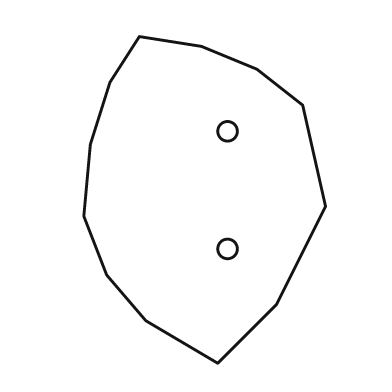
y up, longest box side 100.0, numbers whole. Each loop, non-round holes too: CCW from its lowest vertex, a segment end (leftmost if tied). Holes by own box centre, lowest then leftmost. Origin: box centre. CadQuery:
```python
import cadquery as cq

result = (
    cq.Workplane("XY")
    .moveTo(4.0, -50.0)
    .lineTo(22.0, -32.0)
    .lineTo(37.0, -2.0)
    .lineTo(30.0, 29.0)
    .lineTo(16.0, 40.0)
    .lineTo(-1.0, 47.0)
    .lineTo(-20.0, 50.0)
    .lineTo(-29.0, 36.0)
    .lineTo(-35.0, 17.0)
    .lineTo(-37.0, -5.0)
    .lineTo(-30.0, -23.0)
    .lineTo(-18.0, -37.0)
    .close()
    .moveTo(7.0, -15.0)
    .circle(3.0)
    .moveTo(7.0, 21.0)
    .circle(3.0)
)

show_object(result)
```